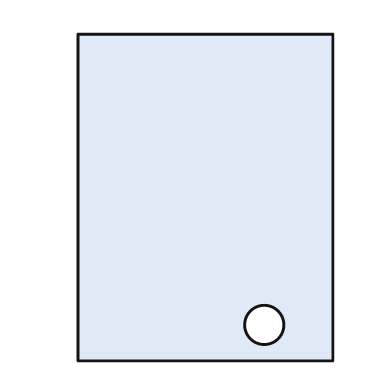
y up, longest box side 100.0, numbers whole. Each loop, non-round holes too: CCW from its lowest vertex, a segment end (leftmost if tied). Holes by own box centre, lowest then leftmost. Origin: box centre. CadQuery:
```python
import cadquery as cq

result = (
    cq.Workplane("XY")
    .moveTo(-39.0, -50.0)
    .lineTo(39.0, -50.0)
    .lineTo(39.0, 50.0)
    .lineTo(-39.0, 50.0)
    .close()
    .moveTo(18.0, -39.0)
    .circle(6.0)
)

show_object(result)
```